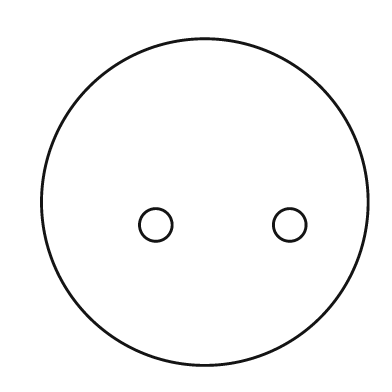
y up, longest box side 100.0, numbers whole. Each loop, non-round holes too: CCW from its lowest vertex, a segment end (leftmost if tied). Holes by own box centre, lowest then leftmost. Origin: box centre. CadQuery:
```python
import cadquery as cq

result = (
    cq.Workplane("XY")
    .moveTo(0.0, 0.0)
    .circle(50.0)
    .moveTo(-15.0, -7.0)
    .circle(5.0)
    .moveTo(26.0, -7.0)
    .circle(5.0)
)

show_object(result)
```